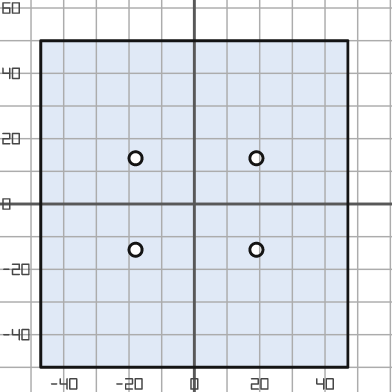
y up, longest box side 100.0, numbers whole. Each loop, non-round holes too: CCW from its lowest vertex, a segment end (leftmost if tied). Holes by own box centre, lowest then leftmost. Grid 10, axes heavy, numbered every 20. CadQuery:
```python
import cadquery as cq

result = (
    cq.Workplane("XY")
    .moveTo(-47.0, -50.0)
    .lineTo(47.0, -50.0)
    .lineTo(47.0, 50.0)
    .lineTo(-47.0, 50.0)
    .close()
    .moveTo(-18.0, -14.0)
    .circle(2.0)
    .moveTo(19.0, -14.0)
    .circle(2.0)
    .moveTo(-18.0, 14.0)
    .circle(2.0)
    .moveTo(19.0, 14.0)
    .circle(2.0)
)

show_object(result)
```